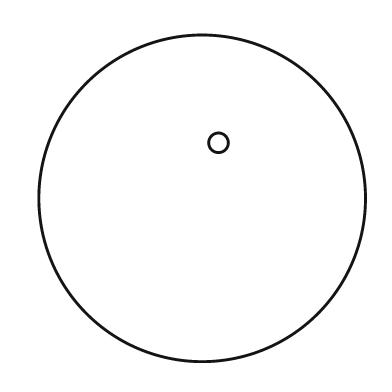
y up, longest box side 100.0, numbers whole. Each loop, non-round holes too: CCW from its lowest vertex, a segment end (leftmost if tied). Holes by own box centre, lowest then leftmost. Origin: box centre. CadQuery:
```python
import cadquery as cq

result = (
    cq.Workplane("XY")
    .moveTo(0.0, 0.0)
    .circle(50.0)
    .moveTo(5.0, 17.0)
    .circle(3.0)
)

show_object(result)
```